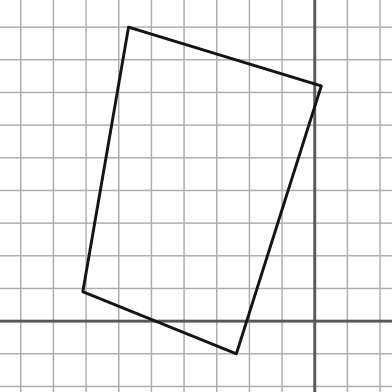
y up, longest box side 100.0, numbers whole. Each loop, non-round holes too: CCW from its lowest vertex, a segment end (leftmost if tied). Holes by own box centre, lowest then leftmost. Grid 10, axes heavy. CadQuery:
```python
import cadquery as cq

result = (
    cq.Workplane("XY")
    .moveTo(-24.0, -10.0)
    .lineTo(2.0, 72.0)
    .lineTo(-57.0, 90.0)
    .lineTo(-71.0, 9.0)
    .close()
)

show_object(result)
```